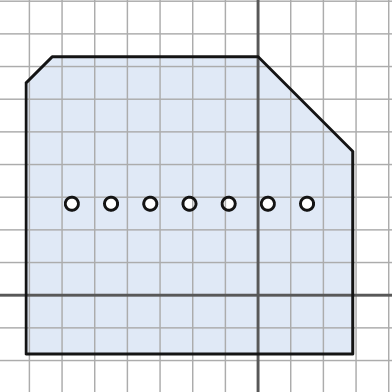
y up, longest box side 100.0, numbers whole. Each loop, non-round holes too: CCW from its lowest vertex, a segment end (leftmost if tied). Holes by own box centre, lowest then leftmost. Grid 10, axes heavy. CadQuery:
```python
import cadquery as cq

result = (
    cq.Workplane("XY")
    .moveTo(-71.0, -18.0)
    .lineTo(29.0, -18.0)
    .lineTo(29.0, 44.0)
    .lineTo(0.0, 73.0)
    .lineTo(-63.0, 73.0)
    .lineTo(-71.0, 65.0)
    .close()
    .moveTo(-57.0, 28.0)
    .circle(2.0)
    .moveTo(-45.0, 28.0)
    .circle(2.0)
    .moveTo(-33.0, 28.0)
    .circle(2.0)
    .moveTo(-21.0, 28.0)
    .circle(2.0)
    .moveTo(-9.0, 28.0)
    .circle(2.0)
    .moveTo(3.0, 28.0)
    .circle(2.0)
    .moveTo(15.0, 28.0)
    .circle(2.0)
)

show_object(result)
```